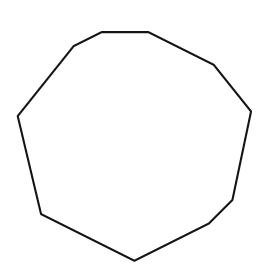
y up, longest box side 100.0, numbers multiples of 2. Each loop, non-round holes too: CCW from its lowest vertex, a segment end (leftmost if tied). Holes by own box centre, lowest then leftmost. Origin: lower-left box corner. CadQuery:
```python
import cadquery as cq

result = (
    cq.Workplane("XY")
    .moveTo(50.0, 0.0)
    .lineTo(82.0, 16.0)
    .lineTo(92.0, 26.0)
    .lineTo(100.0, 64.0)
    .lineTo(84.0, 84.0)
    .lineTo(56.0, 98.0)
    .lineTo(36.0, 98.0)
    .lineTo(24.0, 92.0)
    .lineTo(0.0, 62.0)
    .lineTo(10.0, 20.0)
    .close()
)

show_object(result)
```